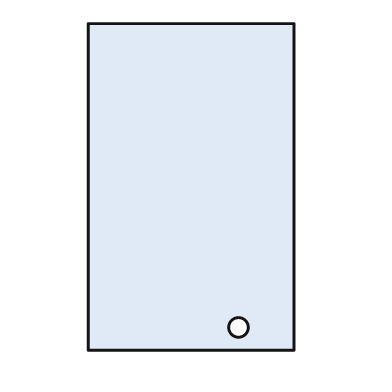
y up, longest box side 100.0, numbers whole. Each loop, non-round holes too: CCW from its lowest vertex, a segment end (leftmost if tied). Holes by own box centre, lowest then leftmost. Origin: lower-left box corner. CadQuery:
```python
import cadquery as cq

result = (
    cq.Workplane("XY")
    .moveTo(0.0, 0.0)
    .lineTo(63.0, 0.0)
    .lineTo(63.0, 100.0)
    .lineTo(0.0, 100.0)
    .close()
    .moveTo(46.0, 7.0)
    .circle(3.0)
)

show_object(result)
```